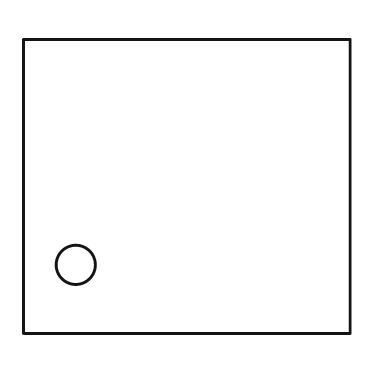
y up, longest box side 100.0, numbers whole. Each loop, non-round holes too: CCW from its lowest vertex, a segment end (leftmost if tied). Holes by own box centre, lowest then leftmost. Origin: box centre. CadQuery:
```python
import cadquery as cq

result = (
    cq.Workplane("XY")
    .moveTo(-50.0, -45.0)
    .lineTo(50.0, -45.0)
    .lineTo(50.0, 45.0)
    .lineTo(-50.0, 45.0)
    .close()
    .moveTo(-34.0, -24.0)
    .circle(6.0)
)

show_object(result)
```